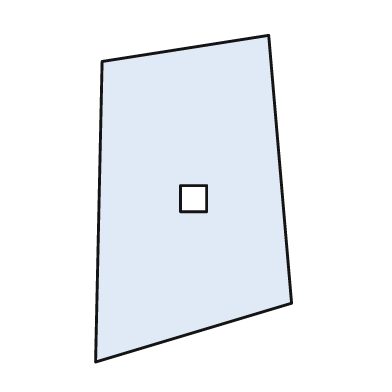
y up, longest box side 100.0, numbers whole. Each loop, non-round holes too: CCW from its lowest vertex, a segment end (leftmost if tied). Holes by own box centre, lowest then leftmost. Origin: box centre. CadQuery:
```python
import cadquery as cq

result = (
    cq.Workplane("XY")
    .moveTo(-30.0, -50.0)
    .lineTo(30.0, -32.0)
    .lineTo(23.0, 50.0)
    .lineTo(-28.0, 42.0)
    .close()
    .moveTo(-4.0, -4.0)
    .lineTo(4.0, -4.0)
    .lineTo(4.0, 4.0)
    .lineTo(-4.0, 4.0)
    .close()
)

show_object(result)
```